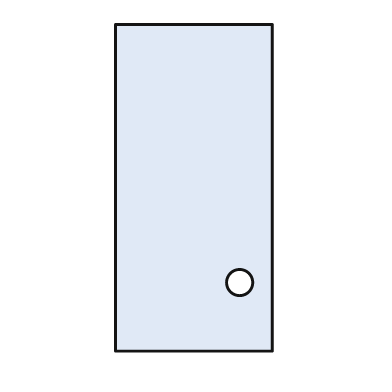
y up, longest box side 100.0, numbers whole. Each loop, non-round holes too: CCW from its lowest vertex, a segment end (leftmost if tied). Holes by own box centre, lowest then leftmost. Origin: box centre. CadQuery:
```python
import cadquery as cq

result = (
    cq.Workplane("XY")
    .moveTo(-24.0, -50.0)
    .lineTo(24.0, -50.0)
    .lineTo(24.0, 50.0)
    .lineTo(-24.0, 50.0)
    .close()
    .moveTo(14.0, -29.0)
    .circle(4.0)
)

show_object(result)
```